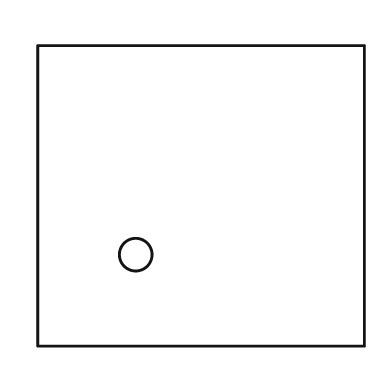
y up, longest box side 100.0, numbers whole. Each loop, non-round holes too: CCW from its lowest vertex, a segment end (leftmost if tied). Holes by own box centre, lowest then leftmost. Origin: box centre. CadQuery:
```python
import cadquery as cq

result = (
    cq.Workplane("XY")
    .moveTo(-50.0, -46.0)
    .lineTo(50.0, -46.0)
    .lineTo(50.0, 46.0)
    .lineTo(-50.0, 46.0)
    .close()
    .moveTo(-20.0, -18.0)
    .circle(5.0)
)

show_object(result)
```